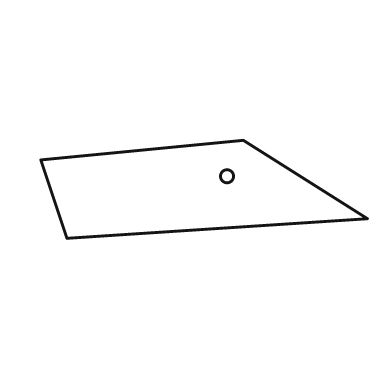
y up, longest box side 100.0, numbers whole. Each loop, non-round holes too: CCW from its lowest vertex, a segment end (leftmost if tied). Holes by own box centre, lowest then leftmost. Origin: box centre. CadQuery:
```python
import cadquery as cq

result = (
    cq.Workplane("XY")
    .moveTo(-42.0, -15.0)
    .lineTo(50.0, -9.0)
    .lineTo(12.0, 15.0)
    .lineTo(-50.0, 9.0)
    .close()
    .moveTo(7.0, 4.0)
    .circle(2.0)
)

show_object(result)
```